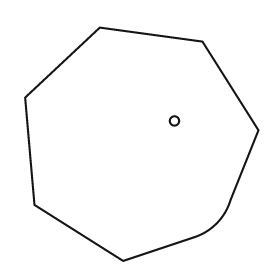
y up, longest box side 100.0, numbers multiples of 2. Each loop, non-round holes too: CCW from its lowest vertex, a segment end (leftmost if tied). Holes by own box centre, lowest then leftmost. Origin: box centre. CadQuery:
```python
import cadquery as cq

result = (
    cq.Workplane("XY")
    .moveTo(-8.0, -50.0)
    .lineTo(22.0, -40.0)
    .threePointArc((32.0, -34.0), (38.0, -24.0))
    .lineTo(50.0, 6.0)
    .lineTo(26.0, 44.0)
    .lineTo(-18.0, 50.0)
    .lineTo(-50.0, 20.0)
    .lineTo(-46.0, -26.0)
    .close()
    .moveTo(14.0, 10.0)
    .circle(2.0)
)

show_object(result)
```